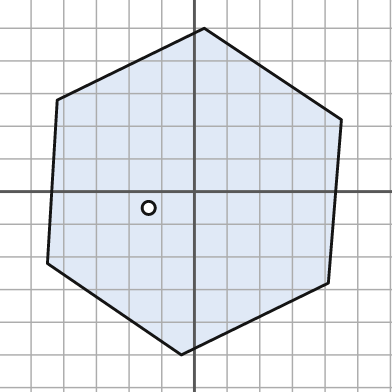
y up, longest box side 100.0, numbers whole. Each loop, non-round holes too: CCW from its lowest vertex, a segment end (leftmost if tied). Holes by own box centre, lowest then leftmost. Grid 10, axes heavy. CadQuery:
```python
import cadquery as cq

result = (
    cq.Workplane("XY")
    .moveTo(-4.0, -50.0)
    .lineTo(41.0, -28.0)
    .lineTo(45.0, 22.0)
    .lineTo(3.0, 50.0)
    .lineTo(-42.0, 28.0)
    .lineTo(-45.0, -22.0)
    .close()
    .moveTo(-14.0, -5.0)
    .circle(2.0)
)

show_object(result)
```